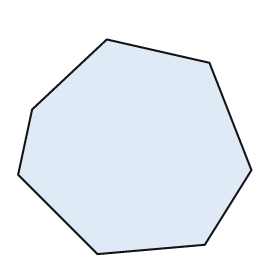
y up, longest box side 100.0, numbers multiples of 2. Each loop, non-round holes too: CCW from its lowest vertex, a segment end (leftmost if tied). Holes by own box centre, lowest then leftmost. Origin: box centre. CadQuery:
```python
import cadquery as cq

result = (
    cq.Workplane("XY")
    .moveTo(-16.0, -46.0)
    .lineTo(30.0, -42.0)
    .lineTo(50.0, -10.0)
    .lineTo(32.0, 36.0)
    .lineTo(-12.0, 46.0)
    .lineTo(-44.0, 16.0)
    .lineTo(-50.0, -12.0)
    .close()
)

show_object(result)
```